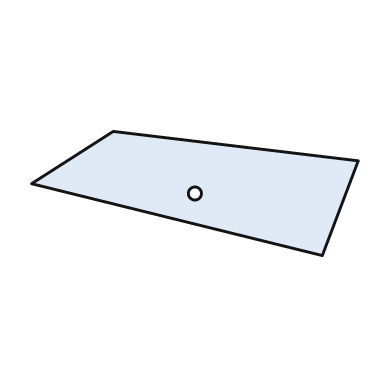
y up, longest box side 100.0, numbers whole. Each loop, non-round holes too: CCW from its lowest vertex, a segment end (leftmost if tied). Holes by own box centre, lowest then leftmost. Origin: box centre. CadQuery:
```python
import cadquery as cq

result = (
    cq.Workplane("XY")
    .moveTo(39.0, -19.0)
    .lineTo(50.0, 10.0)
    .lineTo(-25.0, 19.0)
    .lineTo(-50.0, 3.0)
    .close()
    .moveTo(0.0, 0.0)
    .circle(2.0)
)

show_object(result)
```